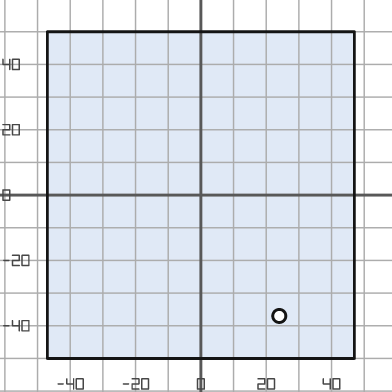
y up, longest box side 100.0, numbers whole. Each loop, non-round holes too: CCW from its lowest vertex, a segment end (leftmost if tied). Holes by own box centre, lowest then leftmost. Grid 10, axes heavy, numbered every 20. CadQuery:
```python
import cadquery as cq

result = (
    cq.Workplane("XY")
    .moveTo(-47.0, -50.0)
    .lineTo(47.0, -50.0)
    .lineTo(47.0, 50.0)
    .lineTo(-47.0, 50.0)
    .close()
    .moveTo(24.0, -37.0)
    .circle(2.0)
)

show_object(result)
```